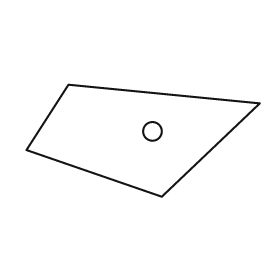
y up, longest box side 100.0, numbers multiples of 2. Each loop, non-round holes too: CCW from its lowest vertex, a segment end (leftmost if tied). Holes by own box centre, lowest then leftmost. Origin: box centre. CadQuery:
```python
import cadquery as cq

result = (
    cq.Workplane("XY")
    .moveTo(8.0, -24.0)
    .lineTo(50.0, 16.0)
    .lineTo(-32.0, 24.0)
    .lineTo(-50.0, -4.0)
    .close()
    .moveTo(4.0, 4.0)
    .circle(4.0)
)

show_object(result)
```